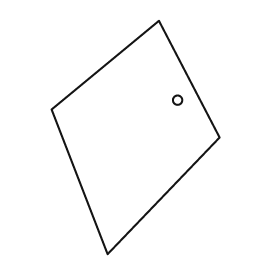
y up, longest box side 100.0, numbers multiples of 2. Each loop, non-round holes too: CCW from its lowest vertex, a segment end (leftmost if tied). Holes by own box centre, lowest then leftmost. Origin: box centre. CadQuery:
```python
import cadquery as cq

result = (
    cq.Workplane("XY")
    .moveTo(-12.0, -50.0)
    .lineTo(36.0, 0.0)
    .lineTo(10.0, 50.0)
    .lineTo(-36.0, 12.0)
    .close()
    .moveTo(18.0, 16.0)
    .circle(2.0)
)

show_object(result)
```